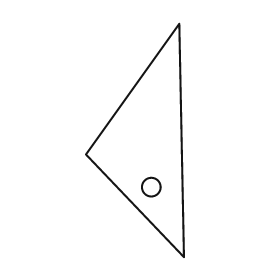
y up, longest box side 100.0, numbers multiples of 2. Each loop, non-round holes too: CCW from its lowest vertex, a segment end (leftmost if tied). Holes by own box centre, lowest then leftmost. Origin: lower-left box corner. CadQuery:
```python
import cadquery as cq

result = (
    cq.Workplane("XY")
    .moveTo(42.0, 0.0)
    .lineTo(40.0, 100.0)
    .lineTo(0.0, 44.0)
    .close()
    .moveTo(28.0, 30.0)
    .circle(4.0)
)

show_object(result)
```